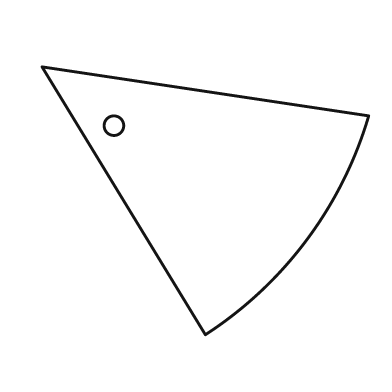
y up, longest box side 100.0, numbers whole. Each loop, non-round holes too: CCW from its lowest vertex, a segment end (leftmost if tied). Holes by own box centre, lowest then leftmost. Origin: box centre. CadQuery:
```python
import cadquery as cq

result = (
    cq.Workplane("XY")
    .moveTo(0.0, -41.0)
    .threePointArc((31.0, -12.0), (50.0, 26.0))
    .lineTo(-50.0, 41.0)
    .close()
    .moveTo(-28.0, 23.0)
    .circle(3.0)
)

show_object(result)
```